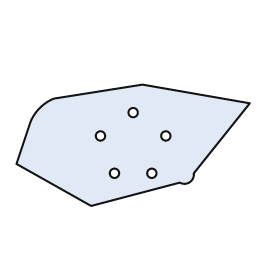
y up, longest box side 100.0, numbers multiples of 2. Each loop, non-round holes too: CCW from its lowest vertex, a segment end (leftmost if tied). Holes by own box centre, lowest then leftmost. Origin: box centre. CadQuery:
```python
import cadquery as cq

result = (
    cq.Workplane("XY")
    .moveTo(-18.0, -26.0)
    .lineTo(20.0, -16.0)
    .threePointArc((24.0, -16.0), (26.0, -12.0))
    .lineTo(50.0, 18.0)
    .lineTo(4.0, 26.0)
    .lineTo(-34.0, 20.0)
    .threePointArc((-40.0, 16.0), (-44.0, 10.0))
    .lineTo(-50.0, -8.0)
    .close()
    .moveTo(-8.0, -12.0)
    .circle(2.0)
    .moveTo(8.0, -12.0)
    .circle(2.0)
    .moveTo(-14.0, 4.0)
    .circle(2.0)
    .moveTo(14.0, 4.0)
    .circle(2.0)
    .moveTo(0.0, 14.0)
    .circle(2.0)
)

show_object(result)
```